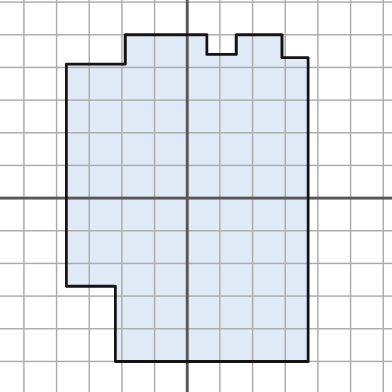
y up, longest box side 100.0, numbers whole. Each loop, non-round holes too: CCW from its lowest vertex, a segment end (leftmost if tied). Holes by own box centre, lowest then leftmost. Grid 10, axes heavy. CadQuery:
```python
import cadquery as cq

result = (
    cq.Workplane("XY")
    .moveTo(-22.0, -50.0)
    .lineTo(37.0, -50.0)
    .lineTo(37.0, 43.0)
    .lineTo(29.0, 43.0)
    .lineTo(29.0, 50.0)
    .lineTo(15.0, 50.0)
    .lineTo(15.0, 44.0)
    .lineTo(6.0, 44.0)
    .lineTo(6.0, 50.0)
    .lineTo(-19.0, 50.0)
    .lineTo(-19.0, 41.0)
    .lineTo(-37.0, 41.0)
    .lineTo(-37.0, -27.0)
    .lineTo(-22.0, -27.0)
    .close()
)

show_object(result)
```